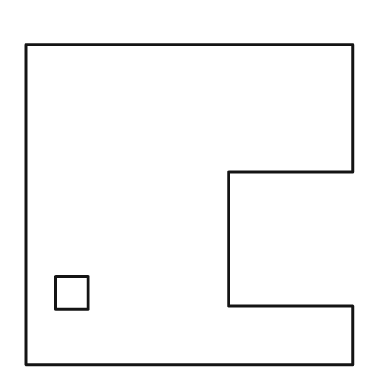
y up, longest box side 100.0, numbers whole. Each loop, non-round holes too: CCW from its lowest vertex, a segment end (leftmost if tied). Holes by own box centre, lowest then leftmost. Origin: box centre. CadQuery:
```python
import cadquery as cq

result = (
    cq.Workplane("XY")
    .moveTo(-50.0, -49.0)
    .lineTo(50.0, -49.0)
    .lineTo(50.0, -31.0)
    .lineTo(12.0, -31.0)
    .lineTo(12.0, 10.0)
    .lineTo(50.0, 10.0)
    .lineTo(50.0, 49.0)
    .lineTo(-50.0, 49.0)
    .close()
    .moveTo(-41.0, -32.0)
    .lineTo(-31.0, -32.0)
    .lineTo(-31.0, -22.0)
    .lineTo(-41.0, -22.0)
    .close()
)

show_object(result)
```